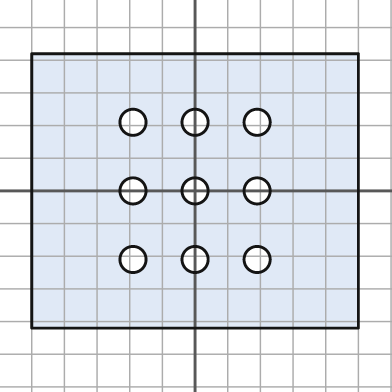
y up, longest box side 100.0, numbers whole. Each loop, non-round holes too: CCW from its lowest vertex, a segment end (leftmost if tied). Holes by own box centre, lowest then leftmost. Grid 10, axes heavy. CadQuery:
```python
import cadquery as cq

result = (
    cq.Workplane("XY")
    .moveTo(-50.0, -42.0)
    .lineTo(50.0, -42.0)
    .lineTo(50.0, 42.0)
    .lineTo(-50.0, 42.0)
    .close()
    .moveTo(-19.0, -21.0)
    .circle(4.0)
    .moveTo(0.0, -21.0)
    .circle(4.0)
    .moveTo(19.0, -21.0)
    .circle(4.0)
    .moveTo(-19.0, 0.0)
    .circle(4.0)
    .moveTo(0.0, 0.0)
    .circle(4.0)
    .moveTo(19.0, 0.0)
    .circle(4.0)
    .moveTo(-19.0, 21.0)
    .circle(4.0)
    .moveTo(0.0, 21.0)
    .circle(4.0)
    .moveTo(19.0, 21.0)
    .circle(4.0)
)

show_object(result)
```